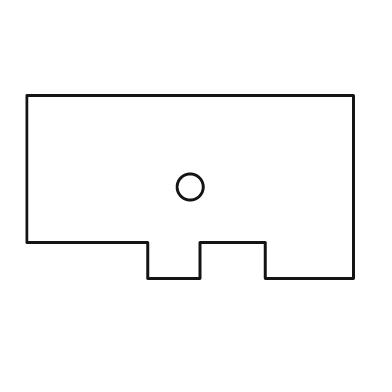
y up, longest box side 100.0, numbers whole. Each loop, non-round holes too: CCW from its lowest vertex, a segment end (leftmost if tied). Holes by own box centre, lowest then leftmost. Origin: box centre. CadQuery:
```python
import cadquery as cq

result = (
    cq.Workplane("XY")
    .moveTo(-13.0, -28.0)
    .lineTo(3.0, -28.0)
    .lineTo(3.0, -17.0)
    .lineTo(23.0, -17.0)
    .lineTo(23.0, -28.0)
    .lineTo(50.0, -28.0)
    .lineTo(50.0, 28.0)
    .lineTo(-50.0, 28.0)
    .lineTo(-50.0, -17.0)
    .lineTo(-13.0, -17.0)
    .close()
    .moveTo(0.0, 0.0)
    .circle(4.0)
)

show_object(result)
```